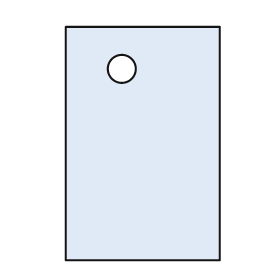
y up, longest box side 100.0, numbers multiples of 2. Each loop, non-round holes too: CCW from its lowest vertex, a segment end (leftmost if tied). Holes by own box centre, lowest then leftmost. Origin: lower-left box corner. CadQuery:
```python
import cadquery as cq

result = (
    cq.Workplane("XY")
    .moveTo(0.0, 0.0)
    .lineTo(66.0, 0.0)
    .lineTo(66.0, 100.0)
    .lineTo(0.0, 100.0)
    .close()
    .moveTo(24.0, 82.0)
    .circle(6.0)
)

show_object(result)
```